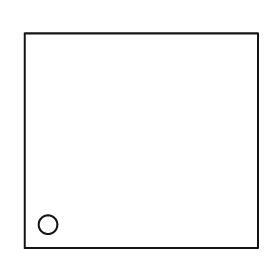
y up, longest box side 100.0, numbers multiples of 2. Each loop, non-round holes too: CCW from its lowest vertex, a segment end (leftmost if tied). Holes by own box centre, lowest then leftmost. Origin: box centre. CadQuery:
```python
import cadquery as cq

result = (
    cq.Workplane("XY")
    .moveTo(-50.0, -46.0)
    .lineTo(50.0, -46.0)
    .lineTo(50.0, 46.0)
    .lineTo(-50.0, 46.0)
    .close()
    .moveTo(-40.0, -36.0)
    .circle(4.0)
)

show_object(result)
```